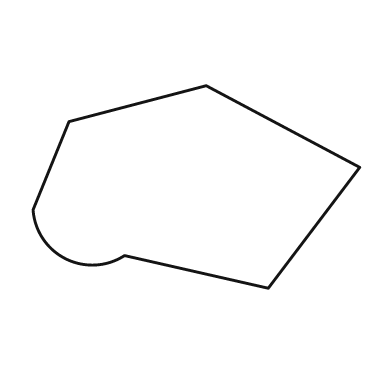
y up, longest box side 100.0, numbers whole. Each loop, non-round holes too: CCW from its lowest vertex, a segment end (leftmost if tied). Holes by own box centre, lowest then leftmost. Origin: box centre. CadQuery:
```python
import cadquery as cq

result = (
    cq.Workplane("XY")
    .moveTo(22.0, -31.0)
    .lineTo(50.0, 6.0)
    .lineTo(3.0, 31.0)
    .lineTo(-39.0, 20.0)
    .lineTo(-50.0, -7.0)
    .threePointArc((-40.0, -22.0), (-22.0, -21.0))
    .close()
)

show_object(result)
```